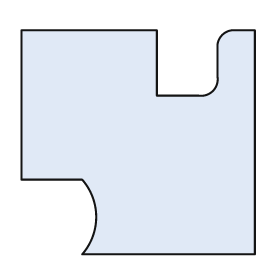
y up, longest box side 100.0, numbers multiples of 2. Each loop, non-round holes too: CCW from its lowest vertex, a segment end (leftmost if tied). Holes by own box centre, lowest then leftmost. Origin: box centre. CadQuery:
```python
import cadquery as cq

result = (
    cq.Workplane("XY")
    .moveTo(-24.0, -48.0)
    .lineTo(50.0, -48.0)
    .lineTo(50.0, 48.0)
    .lineTo(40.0, 48.0)
    .threePointArc((36.0, 46.0), (34.0, 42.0))
    .lineTo(34.0, 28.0)
    .threePointArc((32.0, 22.0), (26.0, 20.0))
    .lineTo(8.0, 20.0)
    .lineTo(8.0, 48.0)
    .lineTo(-50.0, 48.0)
    .lineTo(-50.0, -16.0)
    .lineTo(-24.0, -16.0)
    .threePointArc((-18.0, -32.0), (-24.0, -48.0))
    .close()
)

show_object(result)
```